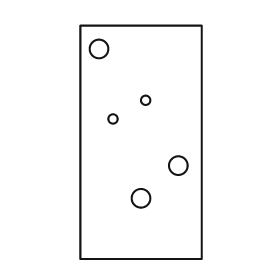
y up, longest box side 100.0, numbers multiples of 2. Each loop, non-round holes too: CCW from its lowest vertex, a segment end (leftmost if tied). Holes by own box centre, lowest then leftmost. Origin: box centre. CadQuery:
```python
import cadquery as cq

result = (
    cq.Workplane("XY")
    .moveTo(-26.0, -50.0)
    .lineTo(26.0, -50.0)
    .lineTo(26.0, 50.0)
    .lineTo(-26.0, 50.0)
    .close()
    .moveTo(0.0, -24.0)
    .circle(4.0)
    .moveTo(16.0, -10.0)
    .circle(4.0)
    .moveTo(-12.0, 10.0)
    .circle(2.0)
    .moveTo(2.0, 18.0)
    .circle(2.0)
    .moveTo(-18.0, 40.0)
    .circle(4.0)
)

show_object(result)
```